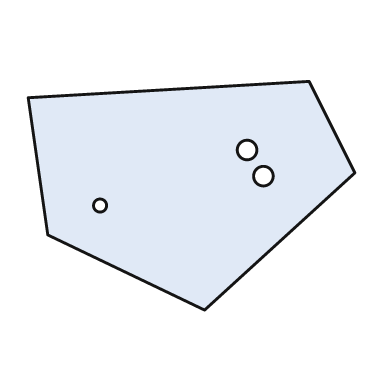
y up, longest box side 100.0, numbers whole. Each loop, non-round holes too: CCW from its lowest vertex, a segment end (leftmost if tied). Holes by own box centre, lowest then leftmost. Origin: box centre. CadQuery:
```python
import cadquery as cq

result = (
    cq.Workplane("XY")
    .moveTo(4.0, -35.0)
    .lineTo(50.0, 7.0)
    .lineTo(36.0, 35.0)
    .lineTo(-50.0, 30.0)
    .lineTo(-44.0, -12.0)
    .close()
    .moveTo(-28.0, -3.0)
    .circle(2.0)
    .moveTo(22.0, 6.0)
    .circle(3.0)
    .moveTo(17.0, 14.0)
    .circle(3.0)
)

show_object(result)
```